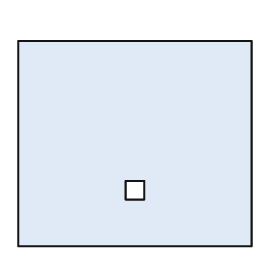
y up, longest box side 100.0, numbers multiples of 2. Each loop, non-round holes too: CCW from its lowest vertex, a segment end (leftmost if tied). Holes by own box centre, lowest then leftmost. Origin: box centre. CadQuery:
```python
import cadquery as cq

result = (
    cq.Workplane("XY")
    .moveTo(-50.0, -44.0)
    .lineTo(50.0, -44.0)
    .lineTo(50.0, 44.0)
    .lineTo(-50.0, 44.0)
    .close()
    .moveTo(-4.0, -24.0)
    .lineTo(4.0, -24.0)
    .lineTo(4.0, -16.0)
    .lineTo(-4.0, -16.0)
    .close()
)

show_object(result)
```